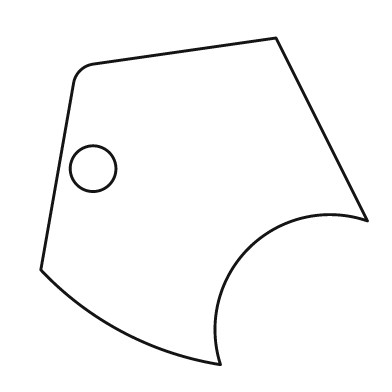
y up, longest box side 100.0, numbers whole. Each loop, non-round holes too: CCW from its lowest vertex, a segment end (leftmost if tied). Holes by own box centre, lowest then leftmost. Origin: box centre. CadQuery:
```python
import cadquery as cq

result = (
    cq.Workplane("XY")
    .moveTo(5.0, -50.0)
    .threePointArc((14.0, -14.0), (50.0, -6.0))
    .lineTo(22.0, 50.0)
    .lineTo(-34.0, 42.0)
    .threePointArc((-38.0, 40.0), (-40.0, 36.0))
    .lineTo(-50.0, -21.0)
    .threePointArc((-25.0, -40.0), (5.0, -50.0))
    .close()
    .moveTo(-34.0, 10.0)
    .circle(7.0)
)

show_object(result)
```